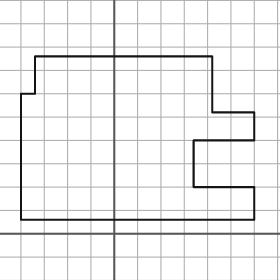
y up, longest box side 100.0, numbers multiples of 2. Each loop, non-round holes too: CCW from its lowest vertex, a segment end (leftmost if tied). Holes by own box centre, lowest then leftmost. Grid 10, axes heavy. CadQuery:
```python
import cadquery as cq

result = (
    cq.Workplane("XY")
    .moveTo(-40.0, 6.0)
    .lineTo(60.0, 6.0)
    .lineTo(60.0, 20.0)
    .lineTo(34.0, 20.0)
    .lineTo(34.0, 40.0)
    .lineTo(60.0, 40.0)
    .lineTo(60.0, 52.0)
    .lineTo(42.0, 52.0)
    .lineTo(42.0, 76.0)
    .lineTo(-34.0, 76.0)
    .lineTo(-34.0, 60.0)
    .lineTo(-40.0, 60.0)
    .close()
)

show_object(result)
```